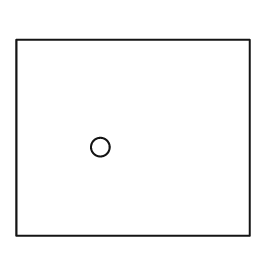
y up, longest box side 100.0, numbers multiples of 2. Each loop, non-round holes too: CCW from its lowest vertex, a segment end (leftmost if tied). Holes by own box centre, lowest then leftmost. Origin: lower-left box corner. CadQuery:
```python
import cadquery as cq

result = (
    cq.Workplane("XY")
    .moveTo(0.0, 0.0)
    .lineTo(100.0, 0.0)
    .lineTo(100.0, 84.0)
    .lineTo(0.0, 84.0)
    .close()
    .moveTo(36.0, 38.0)
    .circle(4.0)
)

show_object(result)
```